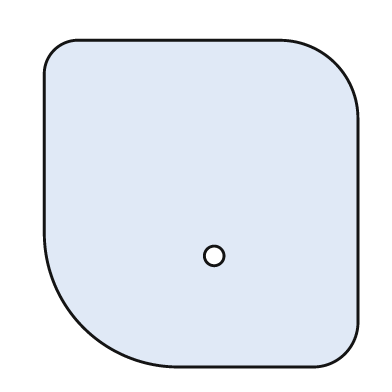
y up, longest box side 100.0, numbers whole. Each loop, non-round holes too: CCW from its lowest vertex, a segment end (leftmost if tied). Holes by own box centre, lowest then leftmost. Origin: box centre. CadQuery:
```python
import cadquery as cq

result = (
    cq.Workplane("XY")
    .moveTo(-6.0, -50.0)
    .lineTo(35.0, -50.0)
    .threePointArc((44.0, -46.0), (48.0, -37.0))
    .lineTo(48.0, 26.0)
    .threePointArc((41.0, 43.0), (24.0, 50.0))
    .lineTo(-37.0, 50.0)
    .threePointArc((-45.0, 47.0), (-48.0, 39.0))
    .lineTo(-48.0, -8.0)
    .threePointArc((-36.0, -38.0), (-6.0, -50.0))
    .close()
    .moveTo(4.0, -16.0)
    .circle(3.0)
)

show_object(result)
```